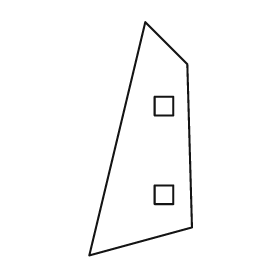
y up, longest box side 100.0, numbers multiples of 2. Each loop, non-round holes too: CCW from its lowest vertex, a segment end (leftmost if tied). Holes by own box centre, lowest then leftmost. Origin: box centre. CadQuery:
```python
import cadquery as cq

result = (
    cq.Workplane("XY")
    .moveTo(-22.0, -50.0)
    .lineTo(22.0, -38.0)
    .lineTo(20.0, 32.0)
    .lineTo(2.0, 50.0)
    .close()
    .moveTo(6.0, -28.0)
    .lineTo(14.0, -28.0)
    .lineTo(14.0, -20.0)
    .lineTo(6.0, -20.0)
    .close()
    .moveTo(6.0, 10.0)
    .lineTo(14.0, 10.0)
    .lineTo(14.0, 18.0)
    .lineTo(6.0, 18.0)
    .close()
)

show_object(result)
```